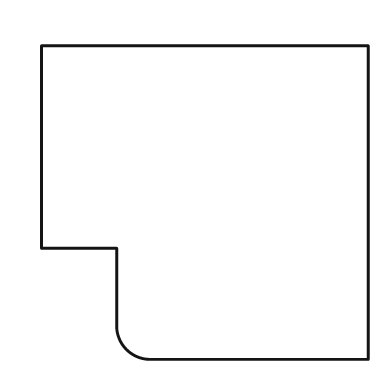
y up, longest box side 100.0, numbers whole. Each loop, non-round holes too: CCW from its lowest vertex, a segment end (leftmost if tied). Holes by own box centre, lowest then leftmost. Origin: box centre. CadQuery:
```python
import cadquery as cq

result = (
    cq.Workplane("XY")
    .moveTo(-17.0, -48.0)
    .lineTo(50.0, -48.0)
    .lineTo(50.0, 48.0)
    .lineTo(-50.0, 48.0)
    .lineTo(-50.0, -14.0)
    .lineTo(-27.0, -14.0)
    .lineTo(-27.0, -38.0)
    .threePointArc((-24.0, -45.0), (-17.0, -48.0))
    .close()
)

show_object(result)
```